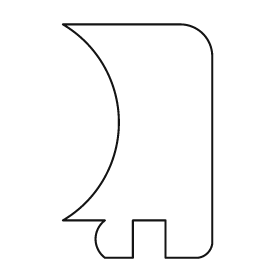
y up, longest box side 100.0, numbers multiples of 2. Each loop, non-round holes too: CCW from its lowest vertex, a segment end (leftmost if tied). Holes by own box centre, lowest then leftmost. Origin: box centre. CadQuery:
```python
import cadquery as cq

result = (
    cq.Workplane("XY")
    .moveTo(-14.0, -50.0)
    .lineTo(-2.0, -50.0)
    .lineTo(-2.0, -34.0)
    .lineTo(12.0, -34.0)
    .lineTo(12.0, -50.0)
    .lineTo(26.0, -50.0)
    .threePointArc((30.0, -48.0), (32.0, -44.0))
    .lineTo(32.0, 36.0)
    .threePointArc((28.0, 46.0), (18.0, 50.0))
    .lineTo(-32.0, 50.0)
    .threePointArc((-8.0, 8.0), (-32.0, -34.0))
    .lineTo(-14.0, -34.0)
    .threePointArc((-18.0, -42.0), (-14.0, -50.0))
    .close()
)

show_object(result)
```